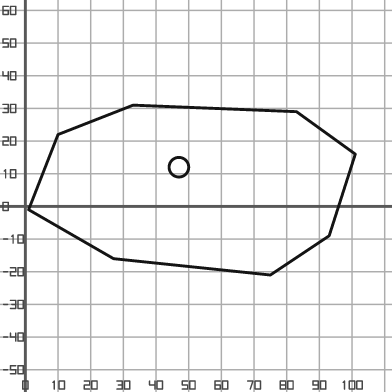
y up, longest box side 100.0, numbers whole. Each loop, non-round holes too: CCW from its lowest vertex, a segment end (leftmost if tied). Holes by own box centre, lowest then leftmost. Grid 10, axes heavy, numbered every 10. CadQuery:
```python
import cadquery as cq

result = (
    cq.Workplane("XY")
    .moveTo(75.0, -21.0)
    .lineTo(93.0, -9.0)
    .lineTo(101.0, 16.0)
    .lineTo(83.0, 29.0)
    .lineTo(33.0, 31.0)
    .lineTo(10.0, 22.0)
    .lineTo(1.0, -1.0)
    .lineTo(27.0, -16.0)
    .close()
    .moveTo(47.0, 12.0)
    .circle(3.0)
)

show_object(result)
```